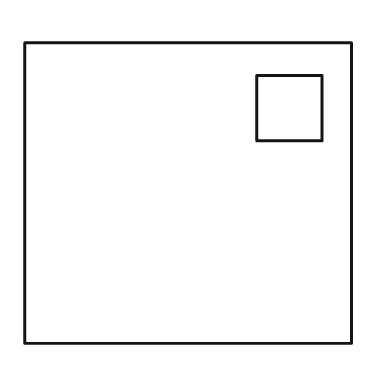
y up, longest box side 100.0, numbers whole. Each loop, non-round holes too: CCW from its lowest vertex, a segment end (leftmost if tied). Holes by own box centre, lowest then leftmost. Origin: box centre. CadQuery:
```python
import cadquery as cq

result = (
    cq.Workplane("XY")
    .moveTo(-50.0, -46.0)
    .lineTo(50.0, -46.0)
    .lineTo(50.0, 46.0)
    .lineTo(-50.0, 46.0)
    .close()
    .moveTo(21.0, 16.0)
    .lineTo(41.0, 16.0)
    .lineTo(41.0, 36.0)
    .lineTo(21.0, 36.0)
    .close()
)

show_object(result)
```